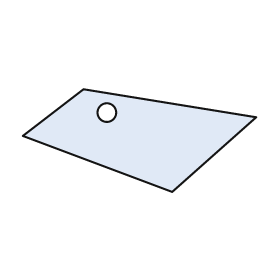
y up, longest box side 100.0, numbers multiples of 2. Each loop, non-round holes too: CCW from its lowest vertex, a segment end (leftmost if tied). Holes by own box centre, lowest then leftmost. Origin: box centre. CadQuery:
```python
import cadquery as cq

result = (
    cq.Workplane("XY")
    .moveTo(14.0, -22.0)
    .lineTo(50.0, 10.0)
    .lineTo(-24.0, 22.0)
    .lineTo(-50.0, 2.0)
    .close()
    .moveTo(-14.0, 12.0)
    .circle(4.0)
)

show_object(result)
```